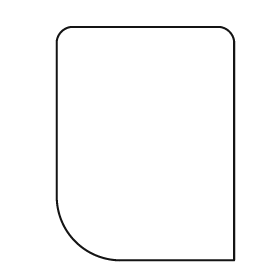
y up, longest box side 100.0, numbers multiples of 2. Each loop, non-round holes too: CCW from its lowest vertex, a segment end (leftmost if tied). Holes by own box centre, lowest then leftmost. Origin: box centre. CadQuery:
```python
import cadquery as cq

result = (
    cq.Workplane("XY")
    .moveTo(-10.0, -50.0)
    .lineTo(38.0, -50.0)
    .lineTo(38.0, 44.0)
    .threePointArc((36.0, 48.0), (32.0, 50.0))
    .lineTo(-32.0, 50.0)
    .threePointArc((-36.0, 48.0), (-38.0, 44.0))
    .lineTo(-38.0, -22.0)
    .threePointArc((-30.0, -42.0), (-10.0, -50.0))
    .close()
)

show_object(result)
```